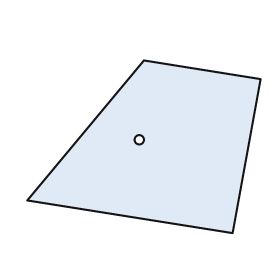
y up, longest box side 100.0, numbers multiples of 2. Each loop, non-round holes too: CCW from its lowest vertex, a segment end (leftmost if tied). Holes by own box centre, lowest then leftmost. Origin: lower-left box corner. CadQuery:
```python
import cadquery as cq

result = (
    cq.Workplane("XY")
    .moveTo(88.0, 0.0)
    .lineTo(100.0, 66.0)
    .lineTo(50.0, 74.0)
    .lineTo(0.0, 14.0)
    .close()
    .moveTo(48.0, 40.0)
    .circle(2.0)
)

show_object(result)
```